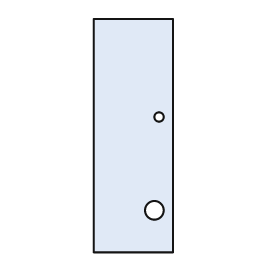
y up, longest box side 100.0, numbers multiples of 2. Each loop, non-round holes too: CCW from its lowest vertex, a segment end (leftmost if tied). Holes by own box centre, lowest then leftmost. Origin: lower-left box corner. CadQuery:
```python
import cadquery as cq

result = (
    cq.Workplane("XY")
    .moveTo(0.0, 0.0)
    .lineTo(34.0, 0.0)
    .lineTo(34.0, 100.0)
    .lineTo(0.0, 100.0)
    .close()
    .moveTo(26.0, 18.0)
    .circle(4.0)
    .moveTo(28.0, 58.0)
    .circle(2.0)
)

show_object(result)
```